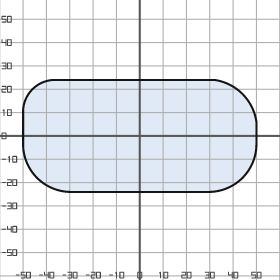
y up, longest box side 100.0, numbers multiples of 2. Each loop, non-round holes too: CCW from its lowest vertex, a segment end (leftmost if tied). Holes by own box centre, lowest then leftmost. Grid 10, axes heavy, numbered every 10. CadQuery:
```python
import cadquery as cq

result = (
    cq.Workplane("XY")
    .moveTo(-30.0, -24.0)
    .lineTo(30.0, -24.0)
    .threePointArc((44.0, -18.0), (50.0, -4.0))
    .lineTo(50.0, 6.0)
    .threePointArc((44.0, 18.0), (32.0, 24.0))
    .lineTo(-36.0, 24.0)
    .threePointArc((-46.0, 20.0), (-50.0, 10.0))
    .lineTo(-50.0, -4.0)
    .threePointArc((-44.0, -18.0), (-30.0, -24.0))
    .close()
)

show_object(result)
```